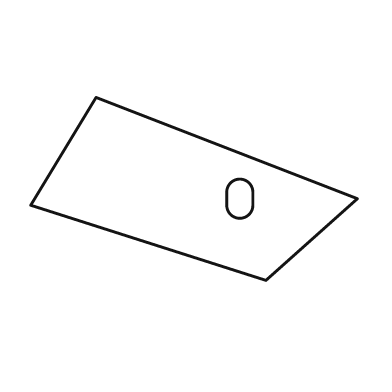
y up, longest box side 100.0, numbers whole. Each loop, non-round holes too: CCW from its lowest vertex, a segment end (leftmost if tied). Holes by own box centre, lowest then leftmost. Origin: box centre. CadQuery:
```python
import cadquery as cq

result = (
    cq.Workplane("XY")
    .moveTo(22.0, -28.0)
    .lineTo(50.0, -3.0)
    .lineTo(-30.0, 28.0)
    .lineTo(-50.0, -5.0)
    .close()
    .moveTo(10.0, -5.0)
    .threePointArc((14.0, -9.0), (18.0, -5.0))
    .lineTo(18.0, -1.0)
    .threePointArc((14.0, 3.0), (10.0, -1.0))
    .close()
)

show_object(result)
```